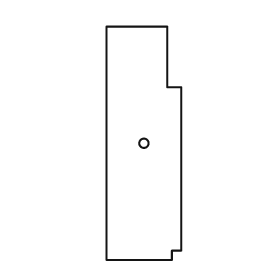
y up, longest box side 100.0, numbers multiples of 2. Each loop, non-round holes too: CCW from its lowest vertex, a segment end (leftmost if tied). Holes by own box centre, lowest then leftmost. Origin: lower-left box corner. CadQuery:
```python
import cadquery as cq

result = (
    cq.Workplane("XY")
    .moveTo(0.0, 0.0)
    .lineTo(28.0, 0.0)
    .lineTo(28.0, 4.0)
    .lineTo(32.0, 4.0)
    .lineTo(32.0, 74.0)
    .lineTo(26.0, 74.0)
    .lineTo(26.0, 100.0)
    .lineTo(0.0, 100.0)
    .close()
    .moveTo(16.0, 50.0)
    .circle(2.0)
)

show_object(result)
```